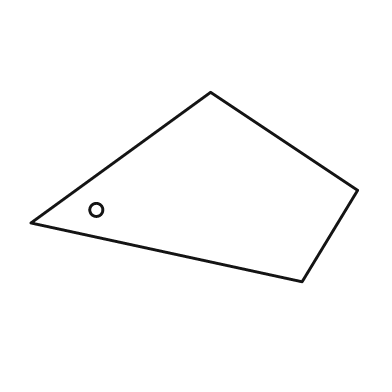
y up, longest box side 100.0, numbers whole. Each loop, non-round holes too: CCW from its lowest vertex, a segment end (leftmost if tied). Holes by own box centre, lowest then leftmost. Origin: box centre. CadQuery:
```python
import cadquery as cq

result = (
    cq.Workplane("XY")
    .moveTo(33.0, -29.0)
    .lineTo(50.0, -1.0)
    .lineTo(5.0, 29.0)
    .lineTo(-50.0, -11.0)
    .close()
    .moveTo(-30.0, -7.0)
    .circle(2.0)
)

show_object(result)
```